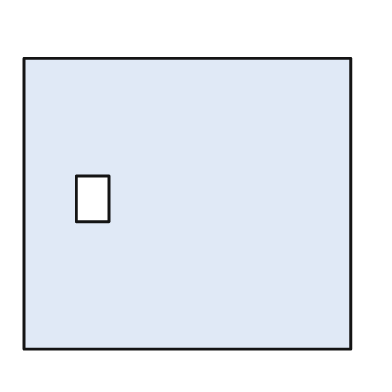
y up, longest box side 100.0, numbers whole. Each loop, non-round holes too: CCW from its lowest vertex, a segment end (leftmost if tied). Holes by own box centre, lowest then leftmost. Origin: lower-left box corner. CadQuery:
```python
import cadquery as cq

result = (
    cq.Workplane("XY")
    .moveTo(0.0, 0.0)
    .lineTo(100.0, 0.0)
    .lineTo(100.0, 89.0)
    .lineTo(0.0, 89.0)
    .close()
    .moveTo(16.0, 39.0)
    .lineTo(26.0, 39.0)
    .lineTo(26.0, 53.0)
    .lineTo(16.0, 53.0)
    .close()
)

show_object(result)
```